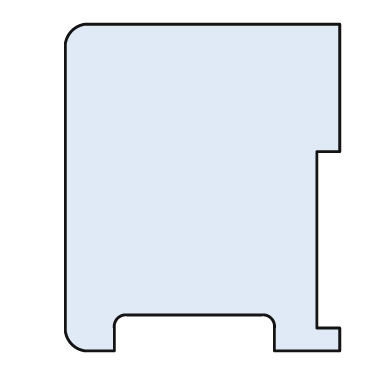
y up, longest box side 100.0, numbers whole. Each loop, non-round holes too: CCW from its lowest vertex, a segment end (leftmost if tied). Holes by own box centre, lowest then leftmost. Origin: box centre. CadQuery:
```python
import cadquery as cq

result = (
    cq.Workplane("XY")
    .moveTo(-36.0, -50.0)
    .lineTo(-27.0, -50.0)
    .lineTo(-27.0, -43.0)
    .threePointArc((-26.0, -40.0), (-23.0, -39.0))
    .lineTo(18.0, -39.0)
    .threePointArc((21.0, -40.0), (22.0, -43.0))
    .lineTo(22.0, -50.0)
    .lineTo(42.0, -50.0)
    .lineTo(42.0, -43.0)
    .lineTo(35.0, -43.0)
    .lineTo(35.0, 11.0)
    .lineTo(42.0, 11.0)
    .lineTo(42.0, 50.0)
    .lineTo(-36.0, 50.0)
    .threePointArc((-40.0, 48.0), (-42.0, 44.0))
    .lineTo(-42.0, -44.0)
    .threePointArc((-40.0, -48.0), (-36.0, -50.0))
    .close()
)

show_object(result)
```